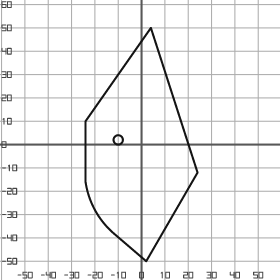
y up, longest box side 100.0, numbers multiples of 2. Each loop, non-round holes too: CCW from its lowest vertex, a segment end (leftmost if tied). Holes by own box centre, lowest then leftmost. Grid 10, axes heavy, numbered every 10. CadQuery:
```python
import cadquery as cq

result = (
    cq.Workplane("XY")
    .moveTo(2.0, -50.0)
    .lineTo(24.0, -12.0)
    .lineTo(4.0, 50.0)
    .lineTo(-24.0, 10.0)
    .lineTo(-24.0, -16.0)
    .threePointArc((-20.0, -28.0), (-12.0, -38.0))
    .close()
    .moveTo(-10.0, 2.0)
    .circle(2.0)
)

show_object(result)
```